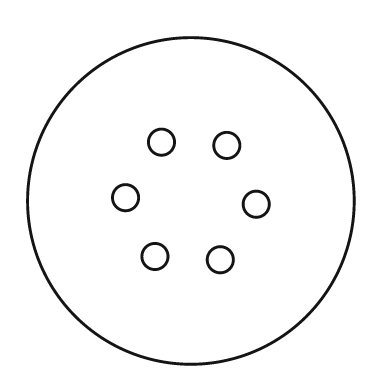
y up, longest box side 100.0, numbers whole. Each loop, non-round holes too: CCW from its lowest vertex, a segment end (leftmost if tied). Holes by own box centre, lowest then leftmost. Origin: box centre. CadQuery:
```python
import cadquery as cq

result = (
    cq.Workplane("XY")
    .moveTo(0.0, 0.0)
    .circle(50.0)
    .moveTo(9.0, -18.0)
    .circle(4.0)
    .moveTo(-11.0, -17.0)
    .circle(4.0)
    .moveTo(20.0, -1.0)
    .circle(4.0)
    .moveTo(-20.0, 1.0)
    .circle(4.0)
    .moveTo(11.0, 17.0)
    .circle(4.0)
    .moveTo(-9.0, 18.0)
    .circle(4.0)
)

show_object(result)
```